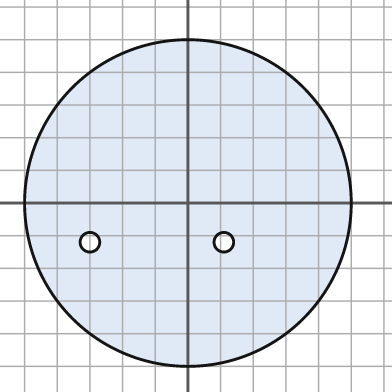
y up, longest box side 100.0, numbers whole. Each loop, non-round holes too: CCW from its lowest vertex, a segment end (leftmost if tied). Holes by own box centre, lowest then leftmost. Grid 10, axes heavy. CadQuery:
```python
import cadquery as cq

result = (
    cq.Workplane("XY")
    .moveTo(0.0, 0.0)
    .circle(50.0)
    .moveTo(-30.0, -12.0)
    .circle(3.0)
    .moveTo(11.0, -12.0)
    .circle(3.0)
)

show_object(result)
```